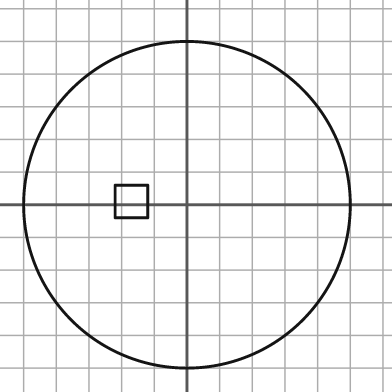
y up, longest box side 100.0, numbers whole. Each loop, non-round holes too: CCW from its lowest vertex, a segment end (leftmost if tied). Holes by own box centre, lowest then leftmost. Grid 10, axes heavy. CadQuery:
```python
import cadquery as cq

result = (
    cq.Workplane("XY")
    .moveTo(0.0, 0.0)
    .circle(50.0)
    .moveTo(-22.0, -4.0)
    .lineTo(-12.0, -4.0)
    .lineTo(-12.0, 6.0)
    .lineTo(-22.0, 6.0)
    .close()
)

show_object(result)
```